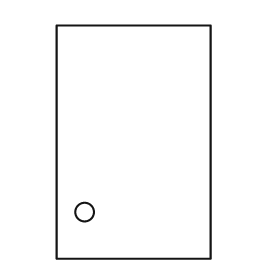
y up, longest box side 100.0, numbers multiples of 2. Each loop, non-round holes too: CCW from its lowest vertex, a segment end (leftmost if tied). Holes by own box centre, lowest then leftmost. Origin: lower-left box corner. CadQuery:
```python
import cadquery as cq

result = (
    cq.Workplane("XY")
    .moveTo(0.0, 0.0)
    .lineTo(66.0, 0.0)
    .lineTo(66.0, 100.0)
    .lineTo(0.0, 100.0)
    .close()
    .moveTo(12.0, 20.0)
    .circle(4.0)
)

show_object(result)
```